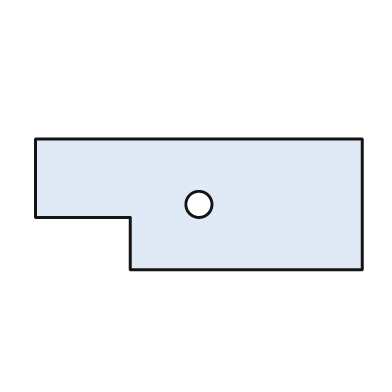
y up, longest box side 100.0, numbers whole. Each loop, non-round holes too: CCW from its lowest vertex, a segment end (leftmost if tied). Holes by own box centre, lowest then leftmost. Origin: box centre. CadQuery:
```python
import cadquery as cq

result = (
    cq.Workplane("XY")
    .moveTo(-21.0, -20.0)
    .lineTo(50.0, -20.0)
    .lineTo(50.0, 20.0)
    .lineTo(-50.0, 20.0)
    .lineTo(-50.0, -4.0)
    .lineTo(-21.0, -4.0)
    .close()
    .moveTo(0.0, 0.0)
    .circle(4.0)
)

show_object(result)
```